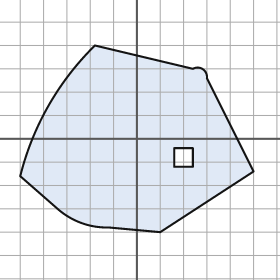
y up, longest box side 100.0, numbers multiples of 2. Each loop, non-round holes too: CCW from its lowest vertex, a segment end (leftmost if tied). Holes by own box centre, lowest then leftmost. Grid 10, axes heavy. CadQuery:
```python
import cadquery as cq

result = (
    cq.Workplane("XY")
    .moveTo(10.0, -40.0)
    .lineTo(50.0, -14.0)
    .lineTo(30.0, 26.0)
    .threePointArc((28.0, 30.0), (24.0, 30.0))
    .lineTo(-18.0, 40.0)
    .threePointArc((-38.0, 14.0), (-50.0, -16.0))
    .lineTo(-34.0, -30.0)
    .threePointArc((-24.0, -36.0), (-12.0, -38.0))
    .close()
    .moveTo(16.0, -12.0)
    .lineTo(24.0, -12.0)
    .lineTo(24.0, -4.0)
    .lineTo(16.0, -4.0)
    .close()
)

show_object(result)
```